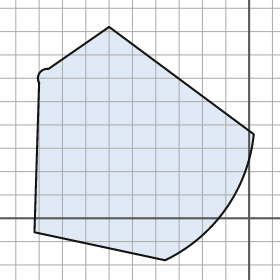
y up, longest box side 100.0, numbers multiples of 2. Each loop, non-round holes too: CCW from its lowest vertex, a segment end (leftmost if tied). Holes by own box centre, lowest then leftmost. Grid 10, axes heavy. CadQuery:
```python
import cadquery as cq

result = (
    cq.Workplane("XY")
    .moveTo(-36.0, -18.0)
    .threePointArc((-10.0, 4.0), (2.0, 36.0))
    .lineTo(-60.0, 82.0)
    .lineTo(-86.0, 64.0)
    .threePointArc((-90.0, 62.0), (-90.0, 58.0))
    .lineTo(-92.0, -6.0)
    .close()
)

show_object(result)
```